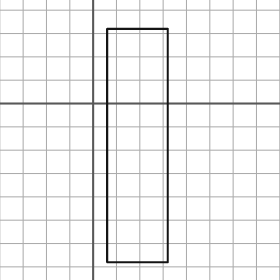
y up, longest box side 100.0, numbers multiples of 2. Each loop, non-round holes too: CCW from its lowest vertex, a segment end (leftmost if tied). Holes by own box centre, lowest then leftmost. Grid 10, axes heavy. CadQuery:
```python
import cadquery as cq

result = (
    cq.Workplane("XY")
    .moveTo(6.0, -68.0)
    .lineTo(32.0, -68.0)
    .lineTo(32.0, 32.0)
    .lineTo(6.0, 32.0)
    .close()
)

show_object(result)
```